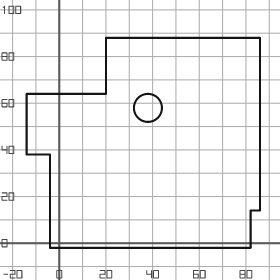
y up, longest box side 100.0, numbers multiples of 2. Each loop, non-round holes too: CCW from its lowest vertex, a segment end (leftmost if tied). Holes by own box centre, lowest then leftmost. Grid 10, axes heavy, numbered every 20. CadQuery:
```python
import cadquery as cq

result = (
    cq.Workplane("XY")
    .moveTo(-4.0, -2.0)
    .lineTo(82.0, -2.0)
    .lineTo(82.0, 14.0)
    .lineTo(86.0, 14.0)
    .lineTo(86.0, 88.0)
    .lineTo(20.0, 88.0)
    .lineTo(20.0, 64.0)
    .lineTo(-14.0, 64.0)
    .lineTo(-14.0, 38.0)
    .lineTo(-4.0, 38.0)
    .close()
    .moveTo(38.0, 58.0)
    .circle(6.0)
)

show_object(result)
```